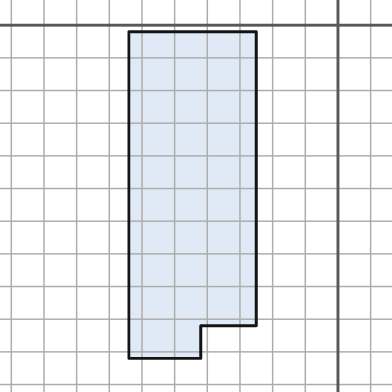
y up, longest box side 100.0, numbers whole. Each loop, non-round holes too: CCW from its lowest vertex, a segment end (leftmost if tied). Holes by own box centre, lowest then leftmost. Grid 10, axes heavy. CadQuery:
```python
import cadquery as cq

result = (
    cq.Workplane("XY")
    .moveTo(-64.0, -102.0)
    .lineTo(-42.0, -102.0)
    .lineTo(-42.0, -92.0)
    .lineTo(-25.0, -92.0)
    .lineTo(-25.0, -2.0)
    .lineTo(-64.0, -2.0)
    .close()
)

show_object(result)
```